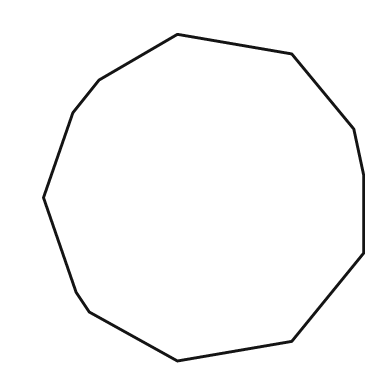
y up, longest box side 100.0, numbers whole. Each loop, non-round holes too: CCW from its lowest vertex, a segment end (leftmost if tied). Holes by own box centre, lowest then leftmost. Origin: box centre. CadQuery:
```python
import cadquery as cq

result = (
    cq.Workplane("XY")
    .moveTo(-8.0, -50.0)
    .lineTo(27.0, -44.0)
    .lineTo(49.0, -17.0)
    .lineTo(49.0, 7.0)
    .lineTo(46.0, 21.0)
    .lineTo(27.0, 44.0)
    .lineTo(-8.0, 50.0)
    .lineTo(-32.0, 36.0)
    .lineTo(-40.0, 26.0)
    .lineTo(-49.0, 0.0)
    .lineTo(-39.0, -29.0)
    .lineTo(-35.0, -35.0)
    .close()
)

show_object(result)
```